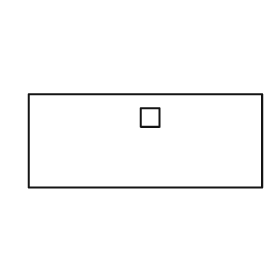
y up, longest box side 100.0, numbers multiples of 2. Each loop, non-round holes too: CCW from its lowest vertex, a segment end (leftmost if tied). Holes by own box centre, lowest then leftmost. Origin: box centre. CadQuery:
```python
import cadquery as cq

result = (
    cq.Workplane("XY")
    .moveTo(-50.0, -20.0)
    .lineTo(50.0, -20.0)
    .lineTo(50.0, 20.0)
    .lineTo(-50.0, 20.0)
    .close()
    .moveTo(-2.0, 6.0)
    .lineTo(6.0, 6.0)
    .lineTo(6.0, 14.0)
    .lineTo(-2.0, 14.0)
    .close()
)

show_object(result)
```